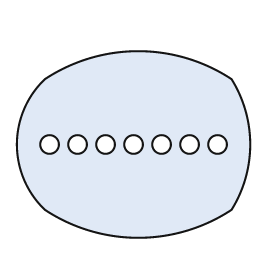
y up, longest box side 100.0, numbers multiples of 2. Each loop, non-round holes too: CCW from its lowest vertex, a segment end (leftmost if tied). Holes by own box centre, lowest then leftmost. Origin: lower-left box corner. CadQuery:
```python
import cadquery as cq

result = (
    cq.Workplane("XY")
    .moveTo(12.0, 12.0)
    .threePointArc((52.0, 0.0), (92.0, 12.0))
    .threePointArc((100.0, 40.0), (92.0, 68.0))
    .threePointArc((52.0, 80.0), (12.0, 68.0))
    .threePointArc((0.0, 40.0), (12.0, 12.0))
    .close()
    .moveTo(14.0, 40.0)
    .circle(4.0)
    .moveTo(26.0, 40.0)
    .circle(4.0)
    .moveTo(38.0, 40.0)
    .circle(4.0)
    .moveTo(50.0, 40.0)
    .circle(4.0)
    .moveTo(62.0, 40.0)
    .circle(4.0)
    .moveTo(74.0, 40.0)
    .circle(4.0)
    .moveTo(86.0, 40.0)
    .circle(4.0)
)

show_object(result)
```